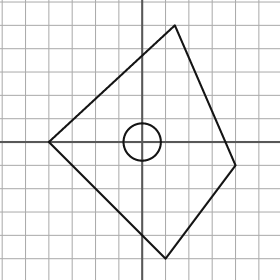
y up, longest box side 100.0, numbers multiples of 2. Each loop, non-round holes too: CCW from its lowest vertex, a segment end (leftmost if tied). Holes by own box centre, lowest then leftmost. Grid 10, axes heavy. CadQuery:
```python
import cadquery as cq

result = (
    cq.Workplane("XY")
    .moveTo(10.0, -50.0)
    .lineTo(40.0, -10.0)
    .lineTo(14.0, 50.0)
    .lineTo(-40.0, 0.0)
    .close()
    .moveTo(0.0, 0.0)
    .circle(8.0)
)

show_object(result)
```